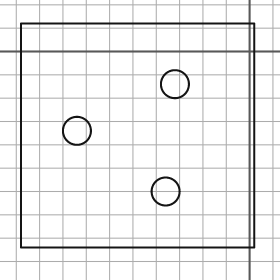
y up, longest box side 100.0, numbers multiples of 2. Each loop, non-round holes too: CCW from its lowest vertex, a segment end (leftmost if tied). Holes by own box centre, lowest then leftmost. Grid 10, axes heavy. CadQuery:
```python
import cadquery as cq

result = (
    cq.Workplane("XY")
    .moveTo(-98.0, -84.0)
    .lineTo(2.0, -84.0)
    .lineTo(2.0, 12.0)
    .lineTo(-98.0, 12.0)
    .close()
    .moveTo(-36.0, -60.0)
    .circle(6.0)
    .moveTo(-74.0, -34.0)
    .circle(6.0)
    .moveTo(-32.0, -14.0)
    .circle(6.0)
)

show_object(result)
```